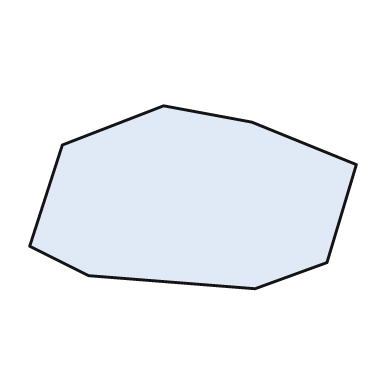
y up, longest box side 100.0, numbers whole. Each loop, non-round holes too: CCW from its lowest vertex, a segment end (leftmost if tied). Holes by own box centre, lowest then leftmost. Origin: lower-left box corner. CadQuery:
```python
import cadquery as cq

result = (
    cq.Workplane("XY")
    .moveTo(69.0, 0.0)
    .lineTo(91.0, 8.0)
    .lineTo(100.0, 38.0)
    .lineTo(68.0, 51.0)
    .lineTo(41.0, 56.0)
    .lineTo(10.0, 44.0)
    .lineTo(0.0, 13.0)
    .lineTo(18.0, 4.0)
    .close()
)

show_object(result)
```